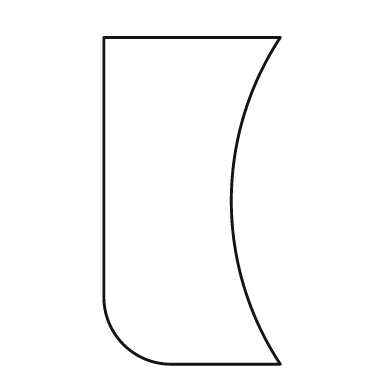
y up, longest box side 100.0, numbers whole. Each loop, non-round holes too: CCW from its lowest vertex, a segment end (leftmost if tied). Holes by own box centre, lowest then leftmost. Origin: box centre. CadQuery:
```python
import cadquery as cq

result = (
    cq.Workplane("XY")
    .moveTo(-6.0, -50.0)
    .lineTo(27.0, -50.0)
    .threePointArc((12.0, 0.0), (27.0, 50.0))
    .lineTo(-27.0, 50.0)
    .lineTo(-27.0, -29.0)
    .threePointArc((-21.0, -44.0), (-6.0, -50.0))
    .close()
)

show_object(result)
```